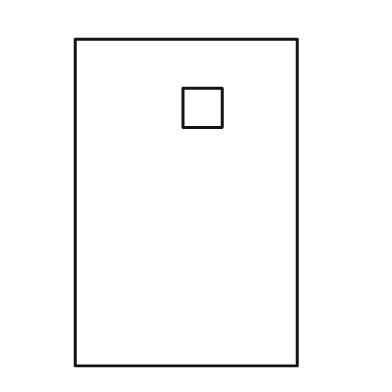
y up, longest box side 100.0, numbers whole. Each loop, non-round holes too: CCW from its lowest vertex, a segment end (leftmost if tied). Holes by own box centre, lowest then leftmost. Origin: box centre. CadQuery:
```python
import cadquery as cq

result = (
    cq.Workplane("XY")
    .moveTo(-34.0, -50.0)
    .lineTo(34.0, -50.0)
    .lineTo(34.0, 50.0)
    .lineTo(-34.0, 50.0)
    .close()
    .moveTo(-1.0, 23.0)
    .lineTo(11.0, 23.0)
    .lineTo(11.0, 35.0)
    .lineTo(-1.0, 35.0)
    .close()
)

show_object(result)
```